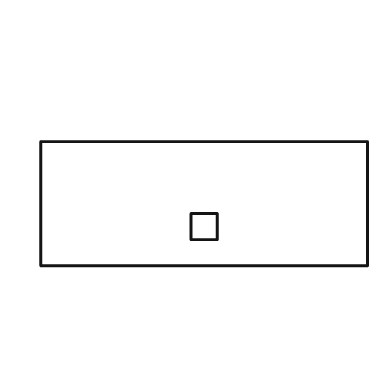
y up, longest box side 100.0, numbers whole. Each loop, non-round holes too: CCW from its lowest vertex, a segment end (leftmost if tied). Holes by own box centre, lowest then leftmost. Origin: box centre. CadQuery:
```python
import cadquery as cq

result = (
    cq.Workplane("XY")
    .moveTo(-50.0, -19.0)
    .lineTo(50.0, -19.0)
    .lineTo(50.0, 19.0)
    .lineTo(-50.0, 19.0)
    .close()
    .moveTo(-4.0, -11.0)
    .lineTo(4.0, -11.0)
    .lineTo(4.0, -3.0)
    .lineTo(-4.0, -3.0)
    .close()
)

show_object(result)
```